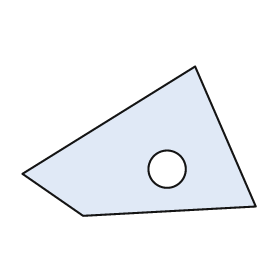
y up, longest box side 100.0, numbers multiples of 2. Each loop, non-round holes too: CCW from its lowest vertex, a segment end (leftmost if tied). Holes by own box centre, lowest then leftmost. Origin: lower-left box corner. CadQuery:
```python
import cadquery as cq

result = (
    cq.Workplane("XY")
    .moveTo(26.0, 0.0)
    .lineTo(100.0, 4.0)
    .lineTo(74.0, 64.0)
    .lineTo(0.0, 18.0)
    .close()
    .moveTo(62.0, 20.0)
    .circle(8.0)
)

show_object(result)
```